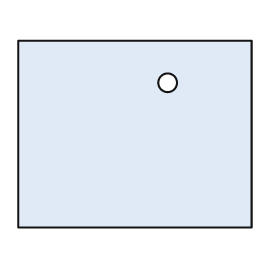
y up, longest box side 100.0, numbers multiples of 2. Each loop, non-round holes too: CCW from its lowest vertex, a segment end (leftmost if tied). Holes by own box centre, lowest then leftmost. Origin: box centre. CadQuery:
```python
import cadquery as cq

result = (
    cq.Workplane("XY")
    .moveTo(-50.0, -40.0)
    .lineTo(50.0, -40.0)
    .lineTo(50.0, 40.0)
    .lineTo(-50.0, 40.0)
    .close()
    .moveTo(14.0, 22.0)
    .circle(4.0)
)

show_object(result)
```